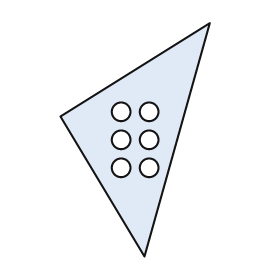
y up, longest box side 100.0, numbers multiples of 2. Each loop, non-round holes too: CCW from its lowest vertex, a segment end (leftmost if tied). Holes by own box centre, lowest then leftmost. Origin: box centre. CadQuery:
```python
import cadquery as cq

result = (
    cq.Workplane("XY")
    .moveTo(4.0, -50.0)
    .lineTo(32.0, 50.0)
    .lineTo(-32.0, 10.0)
    .close()
    .moveTo(-6.0, -12.0)
    .circle(4.0)
    .moveTo(6.0, -12.0)
    .circle(4.0)
    .moveTo(-6.0, 0.0)
    .circle(4.0)
    .moveTo(6.0, 0.0)
    .circle(4.0)
    .moveTo(-6.0, 12.0)
    .circle(4.0)
    .moveTo(6.0, 12.0)
    .circle(4.0)
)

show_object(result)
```